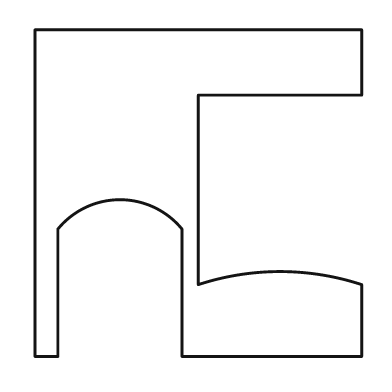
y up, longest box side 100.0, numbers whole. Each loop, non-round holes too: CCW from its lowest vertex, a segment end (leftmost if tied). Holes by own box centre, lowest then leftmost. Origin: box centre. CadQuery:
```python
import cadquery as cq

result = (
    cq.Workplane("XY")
    .moveTo(-50.0, -50.0)
    .lineTo(-43.0, -50.0)
    .lineTo(-43.0, -11.0)
    .threePointArc((-24.0, -2.0), (-5.0, -11.0))
    .lineTo(-5.0, -50.0)
    .lineTo(50.0, -50.0)
    .lineTo(50.0, -28.0)
    .threePointArc((25.0, -24.0), (0.0, -28.0))
    .lineTo(0.0, 30.0)
    .lineTo(50.0, 30.0)
    .lineTo(50.0, 50.0)
    .lineTo(-50.0, 50.0)
    .close()
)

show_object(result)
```